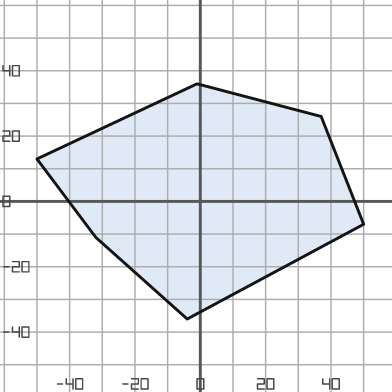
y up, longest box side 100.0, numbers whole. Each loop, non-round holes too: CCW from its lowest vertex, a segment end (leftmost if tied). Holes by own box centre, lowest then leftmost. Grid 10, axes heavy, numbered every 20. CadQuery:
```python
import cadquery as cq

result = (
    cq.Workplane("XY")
    .moveTo(-4.0, -36.0)
    .lineTo(50.0, -7.0)
    .lineTo(37.0, 26.0)
    .lineTo(-1.0, 36.0)
    .lineTo(-50.0, 13.0)
    .lineTo(-32.0, -11.0)
    .close()
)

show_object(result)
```